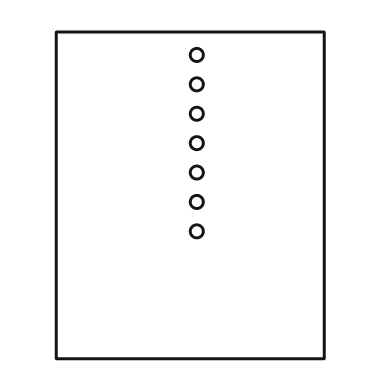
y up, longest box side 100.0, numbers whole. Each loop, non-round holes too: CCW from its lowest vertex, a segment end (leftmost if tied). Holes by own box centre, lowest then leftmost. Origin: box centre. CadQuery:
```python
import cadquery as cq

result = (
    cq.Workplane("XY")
    .moveTo(-41.0, -50.0)
    .lineTo(41.0, -50.0)
    .lineTo(41.0, 50.0)
    .lineTo(-41.0, 50.0)
    .close()
    .moveTo(2.0, -11.0)
    .circle(2.0)
    .moveTo(2.0, -2.0)
    .circle(2.0)
    .moveTo(2.0, 7.0)
    .circle(2.0)
    .moveTo(2.0, 16.0)
    .circle(2.0)
    .moveTo(2.0, 25.0)
    .circle(2.0)
    .moveTo(2.0, 34.0)
    .circle(2.0)
    .moveTo(2.0, 43.0)
    .circle(2.0)
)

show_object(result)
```